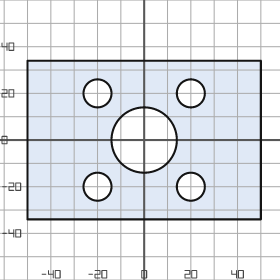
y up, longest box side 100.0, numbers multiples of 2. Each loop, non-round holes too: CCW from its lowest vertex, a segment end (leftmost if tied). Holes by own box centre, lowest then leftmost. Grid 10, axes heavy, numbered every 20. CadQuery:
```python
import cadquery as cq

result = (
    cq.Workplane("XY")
    .moveTo(-50.0, -34.0)
    .lineTo(50.0, -34.0)
    .lineTo(50.0, 34.0)
    .lineTo(-50.0, 34.0)
    .close()
    .moveTo(-20.0, -20.0)
    .circle(6.0)
    .moveTo(20.0, -20.0)
    .circle(6.0)
    .moveTo(0.0, 0.0)
    .circle(14.0)
    .moveTo(-20.0, 20.0)
    .circle(6.0)
    .moveTo(20.0, 20.0)
    .circle(6.0)
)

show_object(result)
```